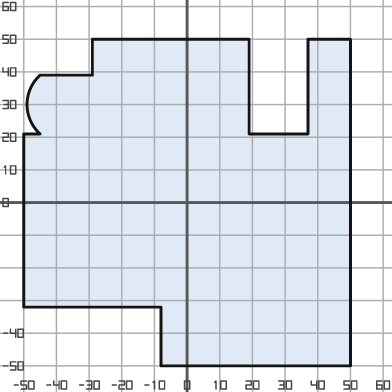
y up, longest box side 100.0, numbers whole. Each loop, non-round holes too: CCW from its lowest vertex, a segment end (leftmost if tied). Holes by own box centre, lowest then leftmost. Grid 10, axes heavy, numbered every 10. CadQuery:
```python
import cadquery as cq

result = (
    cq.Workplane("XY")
    .moveTo(-8.0, -50.0)
    .lineTo(50.0, -50.0)
    .lineTo(50.0, 50.0)
    .lineTo(37.0, 50.0)
    .lineTo(37.0, 21.0)
    .lineTo(19.0, 21.0)
    .lineTo(19.0, 50.0)
    .lineTo(-29.0, 50.0)
    .lineTo(-29.0, 39.0)
    .lineTo(-45.0, 39.0)
    .threePointArc((-49.0, 30.0), (-45.0, 21.0))
    .lineTo(-50.0, 21.0)
    .lineTo(-50.0, -32.0)
    .lineTo(-8.0, -32.0)
    .close()
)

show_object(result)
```